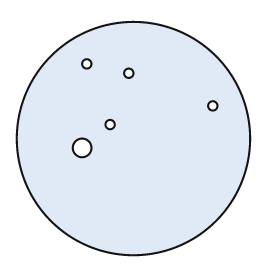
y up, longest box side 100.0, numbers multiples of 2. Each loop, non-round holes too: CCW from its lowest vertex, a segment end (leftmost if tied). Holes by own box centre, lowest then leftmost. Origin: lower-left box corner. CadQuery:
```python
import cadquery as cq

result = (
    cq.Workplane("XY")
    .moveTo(50.0, 50.0)
    .circle(50.0)
    .moveTo(28.0, 46.0)
    .circle(4.0)
    .moveTo(40.0, 56.0)
    .circle(2.0)
    .moveTo(84.0, 64.0)
    .circle(2.0)
    .moveTo(48.0, 78.0)
    .circle(2.0)
    .moveTo(30.0, 82.0)
    .circle(2.0)
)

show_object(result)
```